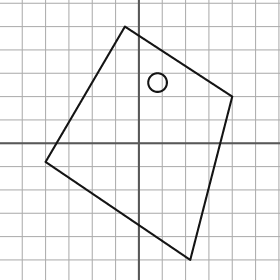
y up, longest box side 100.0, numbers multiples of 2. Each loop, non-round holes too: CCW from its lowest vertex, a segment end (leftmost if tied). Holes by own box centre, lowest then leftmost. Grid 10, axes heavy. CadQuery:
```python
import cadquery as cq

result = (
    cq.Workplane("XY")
    .moveTo(22.0, -50.0)
    .lineTo(40.0, 20.0)
    .lineTo(-6.0, 50.0)
    .lineTo(-40.0, -8.0)
    .close()
    .moveTo(8.0, 26.0)
    .circle(4.0)
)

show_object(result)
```